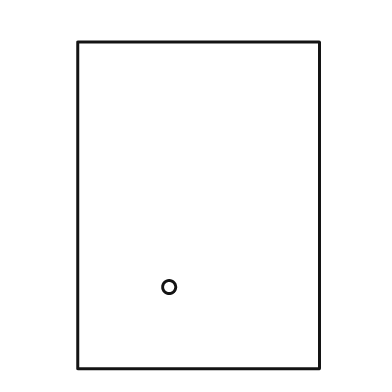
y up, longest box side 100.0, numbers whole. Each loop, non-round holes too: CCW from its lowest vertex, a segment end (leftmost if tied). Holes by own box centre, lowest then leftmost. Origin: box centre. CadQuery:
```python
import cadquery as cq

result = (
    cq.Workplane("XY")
    .moveTo(-37.0, -50.0)
    .lineTo(37.0, -50.0)
    .lineTo(37.0, 50.0)
    .lineTo(-37.0, 50.0)
    .close()
    .moveTo(-9.0, -25.0)
    .circle(2.0)
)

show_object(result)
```